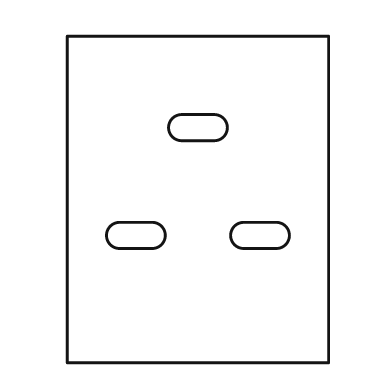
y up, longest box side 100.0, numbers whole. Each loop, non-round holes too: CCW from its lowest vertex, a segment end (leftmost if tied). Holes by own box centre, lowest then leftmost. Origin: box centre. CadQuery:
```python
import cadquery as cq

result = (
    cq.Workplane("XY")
    .moveTo(-40.0, -50.0)
    .lineTo(40.0, -50.0)
    .lineTo(40.0, 50.0)
    .lineTo(-40.0, 50.0)
    .close()
    .moveTo(-24.0, -15.0)
    .lineTo(-14.0, -15.0)
    .threePointArc((-10.0, -11.0), (-14.0, -7.0))
    .lineTo(-24.0, -7.0)
    .threePointArc((-28.0, -11.0), (-24.0, -15.0))
    .close()
    .moveTo(14.0, -15.0)
    .lineTo(24.0, -15.0)
    .threePointArc((28.0, -11.0), (24.0, -7.0))
    .lineTo(14.0, -7.0)
    .threePointArc((10.0, -11.0), (14.0, -15.0))
    .close()
    .moveTo(-5.0, 18.0)
    .lineTo(5.0, 18.0)
    .threePointArc((9.0, 22.0), (5.0, 26.0))
    .lineTo(-5.0, 26.0)
    .threePointArc((-9.0, 22.0), (-5.0, 18.0))
    .close()
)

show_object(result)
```